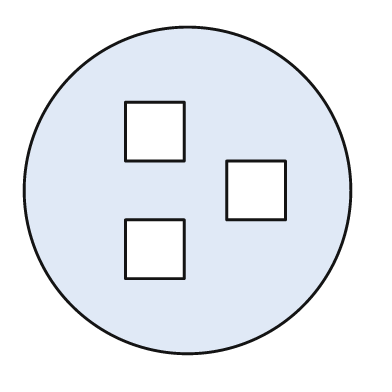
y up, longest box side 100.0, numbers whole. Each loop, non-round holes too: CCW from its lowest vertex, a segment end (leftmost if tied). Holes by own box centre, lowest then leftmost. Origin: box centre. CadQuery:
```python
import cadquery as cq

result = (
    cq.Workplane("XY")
    .moveTo(0.0, 0.0)
    .circle(50.0)
    .moveTo(-19.0, -27.0)
    .lineTo(-1.0, -27.0)
    .lineTo(-1.0, -9.0)
    .lineTo(-19.0, -9.0)
    .close()
    .moveTo(12.0, -9.0)
    .lineTo(30.0, -9.0)
    .lineTo(30.0, 9.0)
    .lineTo(12.0, 9.0)
    .close()
    .moveTo(-19.0, 9.0)
    .lineTo(-1.0, 9.0)
    .lineTo(-1.0, 27.0)
    .lineTo(-19.0, 27.0)
    .close()
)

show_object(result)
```